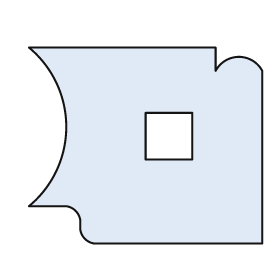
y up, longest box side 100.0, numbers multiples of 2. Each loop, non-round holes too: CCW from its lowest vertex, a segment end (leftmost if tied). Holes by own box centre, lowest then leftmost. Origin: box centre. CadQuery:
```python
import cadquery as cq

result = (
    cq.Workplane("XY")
    .moveTo(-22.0, -42.0)
    .lineTo(50.0, -42.0)
    .lineTo(50.0, 32.0)
    .threePointArc((40.0, 38.0), (30.0, 32.0))
    .lineTo(30.0, 42.0)
    .lineTo(-50.0, 42.0)
    .threePointArc((-34.0, 8.0), (-50.0, -26.0))
    .lineTo(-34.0, -26.0)
    .threePointArc((-30.0, -28.0), (-28.0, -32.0))
    .lineTo(-28.0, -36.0)
    .threePointArc((-26.0, -40.0), (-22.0, -42.0))
    .close()
    .moveTo(0.0, -6.0)
    .lineTo(20.0, -6.0)
    .lineTo(20.0, 14.0)
    .lineTo(0.0, 14.0)
    .close()
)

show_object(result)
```